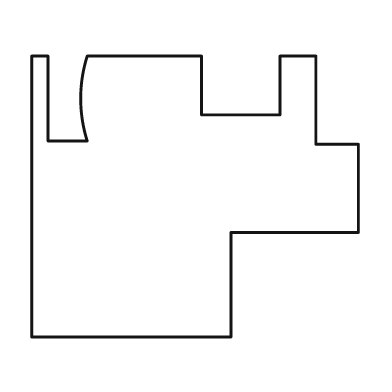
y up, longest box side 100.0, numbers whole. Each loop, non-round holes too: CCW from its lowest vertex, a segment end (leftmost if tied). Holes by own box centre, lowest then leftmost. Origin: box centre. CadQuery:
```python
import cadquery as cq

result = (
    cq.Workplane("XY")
    .moveTo(-50.0, -43.0)
    .lineTo(11.0, -43.0)
    .lineTo(11.0, -11.0)
    .lineTo(50.0, -11.0)
    .lineTo(50.0, 16.0)
    .lineTo(37.0, 16.0)
    .lineTo(37.0, 43.0)
    .lineTo(26.0, 43.0)
    .lineTo(26.0, 25.0)
    .lineTo(2.0, 25.0)
    .lineTo(2.0, 43.0)
    .lineTo(-33.0, 43.0)
    .threePointArc((-35.0, 30.0), (-33.0, 17.0))
    .lineTo(-45.0, 17.0)
    .lineTo(-45.0, 43.0)
    .lineTo(-50.0, 43.0)
    .close()
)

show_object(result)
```